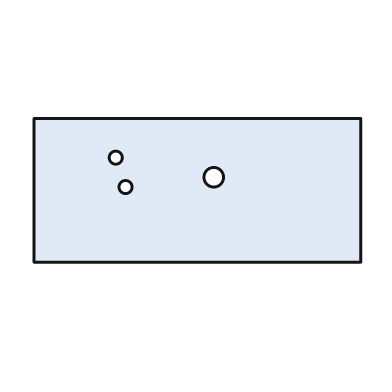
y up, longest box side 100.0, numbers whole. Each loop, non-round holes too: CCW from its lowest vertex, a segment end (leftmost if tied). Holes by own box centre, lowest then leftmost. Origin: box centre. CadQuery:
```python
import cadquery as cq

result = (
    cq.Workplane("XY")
    .moveTo(-50.0, -22.0)
    .lineTo(50.0, -22.0)
    .lineTo(50.0, 22.0)
    .lineTo(-50.0, 22.0)
    .close()
    .moveTo(-22.0, 1.0)
    .circle(2.0)
    .moveTo(5.0, 4.0)
    .circle(3.0)
    .moveTo(-25.0, 10.0)
    .circle(2.0)
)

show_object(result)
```